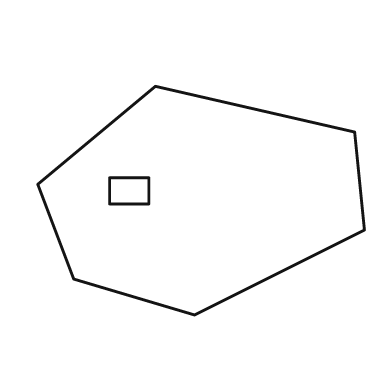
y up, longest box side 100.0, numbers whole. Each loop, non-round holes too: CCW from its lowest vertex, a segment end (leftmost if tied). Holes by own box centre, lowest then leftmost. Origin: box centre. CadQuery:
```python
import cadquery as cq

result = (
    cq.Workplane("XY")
    .moveTo(-2.0, -35.0)
    .lineTo(50.0, -9.0)
    .lineTo(47.0, 21.0)
    .lineTo(-14.0, 35.0)
    .lineTo(-50.0, 5.0)
    .lineTo(-39.0, -24.0)
    .close()
    .moveTo(-28.0, -1.0)
    .lineTo(-16.0, -1.0)
    .lineTo(-16.0, 7.0)
    .lineTo(-28.0, 7.0)
    .close()
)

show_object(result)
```